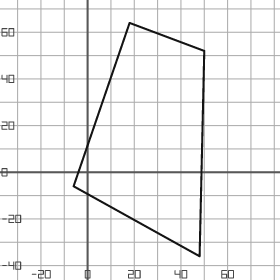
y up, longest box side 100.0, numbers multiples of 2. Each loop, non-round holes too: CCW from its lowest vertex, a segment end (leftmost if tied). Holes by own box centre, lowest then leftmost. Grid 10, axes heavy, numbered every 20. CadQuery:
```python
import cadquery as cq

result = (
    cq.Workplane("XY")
    .moveTo(48.0, -36.0)
    .lineTo(50.0, 52.0)
    .lineTo(18.0, 64.0)
    .lineTo(-6.0, -6.0)
    .close()
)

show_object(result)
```